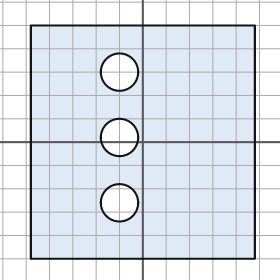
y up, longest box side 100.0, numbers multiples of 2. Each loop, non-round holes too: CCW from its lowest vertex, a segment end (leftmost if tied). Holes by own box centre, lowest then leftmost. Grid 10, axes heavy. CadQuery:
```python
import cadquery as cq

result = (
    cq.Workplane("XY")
    .moveTo(-48.0, -50.0)
    .lineTo(48.0, -50.0)
    .lineTo(48.0, 50.0)
    .lineTo(-48.0, 50.0)
    .close()
    .moveTo(-10.0, -26.0)
    .circle(8.0)
    .moveTo(-10.0, 2.0)
    .circle(8.0)
    .moveTo(-10.0, 30.0)
    .circle(8.0)
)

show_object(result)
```